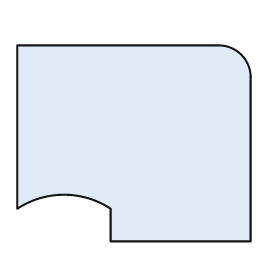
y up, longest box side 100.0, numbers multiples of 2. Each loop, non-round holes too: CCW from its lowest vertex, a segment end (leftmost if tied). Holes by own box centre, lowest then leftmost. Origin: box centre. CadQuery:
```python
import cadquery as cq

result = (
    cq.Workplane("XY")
    .moveTo(-10.0, -42.0)
    .lineTo(50.0, -42.0)
    .lineTo(50.0, 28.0)
    .threePointArc((46.0, 38.0), (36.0, 42.0))
    .lineTo(-50.0, 42.0)
    .lineTo(-50.0, -28.0)
    .threePointArc((-30.0, -22.0), (-10.0, -28.0))
    .close()
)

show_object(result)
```